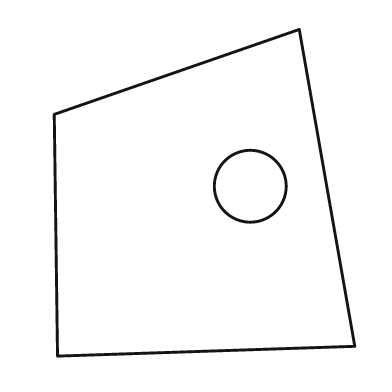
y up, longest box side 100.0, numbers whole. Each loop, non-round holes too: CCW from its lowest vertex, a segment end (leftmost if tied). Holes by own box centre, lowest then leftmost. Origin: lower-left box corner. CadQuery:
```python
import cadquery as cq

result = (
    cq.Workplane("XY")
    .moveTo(1.0, 0.0)
    .lineTo(92.0, 3.0)
    .lineTo(75.0, 100.0)
    .lineTo(0.0, 74.0)
    .close()
    .moveTo(60.0, 52.0)
    .circle(11.0)
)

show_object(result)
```